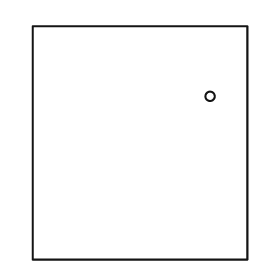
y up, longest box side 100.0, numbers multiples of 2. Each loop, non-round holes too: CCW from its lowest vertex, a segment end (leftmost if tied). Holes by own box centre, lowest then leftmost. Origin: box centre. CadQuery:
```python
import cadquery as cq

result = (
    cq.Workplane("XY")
    .moveTo(-46.0, -50.0)
    .lineTo(46.0, -50.0)
    .lineTo(46.0, 50.0)
    .lineTo(-46.0, 50.0)
    .close()
    .moveTo(30.0, 20.0)
    .circle(2.0)
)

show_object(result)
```